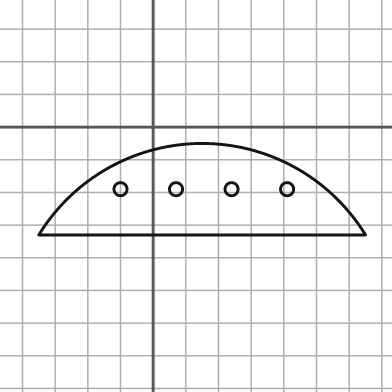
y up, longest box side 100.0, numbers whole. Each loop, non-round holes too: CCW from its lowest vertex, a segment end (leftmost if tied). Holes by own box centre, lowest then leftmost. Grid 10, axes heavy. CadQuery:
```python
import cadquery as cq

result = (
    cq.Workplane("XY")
    .moveTo(-35.0, -33.0)
    .lineTo(65.0, -33.0)
    .threePointArc((15.0, -5.0), (-35.0, -33.0))
    .close()
    .moveTo(-10.0, -19.0)
    .circle(2.0)
    .moveTo(7.0, -19.0)
    .circle(2.0)
    .moveTo(24.0, -19.0)
    .circle(2.0)
    .moveTo(41.0, -19.0)
    .circle(2.0)
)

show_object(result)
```